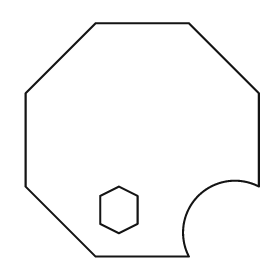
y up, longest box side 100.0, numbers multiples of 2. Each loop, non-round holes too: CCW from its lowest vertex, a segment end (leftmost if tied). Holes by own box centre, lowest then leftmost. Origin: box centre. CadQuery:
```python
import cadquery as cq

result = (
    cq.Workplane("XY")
    .moveTo(-20.0, -50.0)
    .lineTo(20.0, -50.0)
    .threePointArc((24.0, -24.0), (50.0, -20.0))
    .lineTo(50.0, 20.0)
    .lineTo(20.0, 50.0)
    .lineTo(-20.0, 50.0)
    .lineTo(-50.0, 20.0)
    .lineTo(-50.0, -20.0)
    .close()
    .moveTo(-10.0, -40.0)
    .lineTo(-2.0, -36.0)
    .lineTo(-2.0, -24.0)
    .lineTo(-10.0, -20.0)
    .lineTo(-18.0, -24.0)
    .lineTo(-18.0, -36.0)
    .close()
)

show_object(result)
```